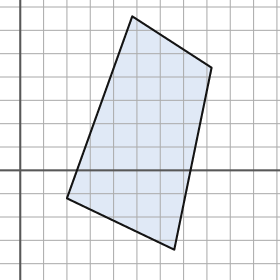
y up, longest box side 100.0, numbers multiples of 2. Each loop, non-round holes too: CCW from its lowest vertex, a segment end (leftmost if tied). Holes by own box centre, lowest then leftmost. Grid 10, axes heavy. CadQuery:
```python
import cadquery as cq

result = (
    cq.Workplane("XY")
    .moveTo(66.0, -34.0)
    .lineTo(82.0, 44.0)
    .lineTo(48.0, 66.0)
    .lineTo(20.0, -12.0)
    .close()
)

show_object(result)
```